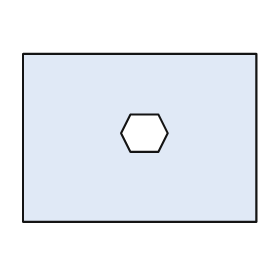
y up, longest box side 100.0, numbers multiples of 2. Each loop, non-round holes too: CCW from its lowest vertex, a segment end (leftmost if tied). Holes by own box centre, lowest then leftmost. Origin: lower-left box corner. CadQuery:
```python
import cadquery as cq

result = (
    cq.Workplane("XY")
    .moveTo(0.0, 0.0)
    .lineTo(100.0, 0.0)
    .lineTo(100.0, 72.0)
    .lineTo(0.0, 72.0)
    .close()
    .moveTo(46.0, 30.0)
    .lineTo(58.0, 30.0)
    .lineTo(62.0, 38.0)
    .lineTo(58.0, 46.0)
    .lineTo(46.0, 46.0)
    .lineTo(42.0, 38.0)
    .close()
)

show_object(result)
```